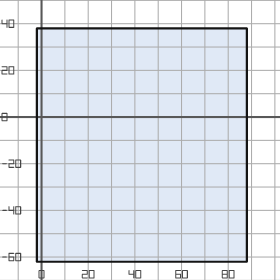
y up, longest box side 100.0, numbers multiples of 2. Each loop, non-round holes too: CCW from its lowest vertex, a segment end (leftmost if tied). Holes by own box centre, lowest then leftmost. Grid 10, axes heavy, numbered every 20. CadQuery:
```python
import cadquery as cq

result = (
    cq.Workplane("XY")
    .moveTo(-2.0, -62.0)
    .lineTo(88.0, -62.0)
    .lineTo(88.0, 38.0)
    .lineTo(-2.0, 38.0)
    .close()
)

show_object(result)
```